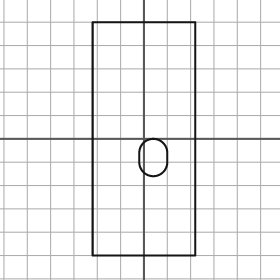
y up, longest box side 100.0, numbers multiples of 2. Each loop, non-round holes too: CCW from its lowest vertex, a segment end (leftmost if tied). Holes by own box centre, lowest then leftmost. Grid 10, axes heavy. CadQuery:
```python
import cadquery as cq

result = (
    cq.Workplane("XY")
    .moveTo(-22.0, -50.0)
    .lineTo(22.0, -50.0)
    .lineTo(22.0, 50.0)
    .lineTo(-22.0, 50.0)
    .close()
    .moveTo(-2.0, -10.0)
    .threePointArc((4.0, -16.0), (10.0, -10.0))
    .lineTo(10.0, -6.0)
    .threePointArc((4.0, 0.0), (-2.0, -6.0))
    .close()
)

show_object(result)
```